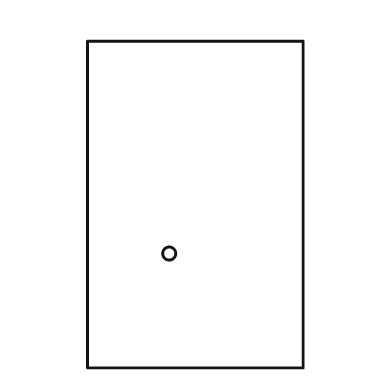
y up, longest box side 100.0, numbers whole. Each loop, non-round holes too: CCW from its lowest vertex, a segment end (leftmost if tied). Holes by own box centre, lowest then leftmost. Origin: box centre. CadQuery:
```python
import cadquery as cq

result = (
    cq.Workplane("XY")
    .moveTo(-33.0, -50.0)
    .lineTo(33.0, -50.0)
    .lineTo(33.0, 50.0)
    .lineTo(-33.0, 50.0)
    .close()
    .moveTo(-8.0, -15.0)
    .circle(2.0)
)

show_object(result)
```